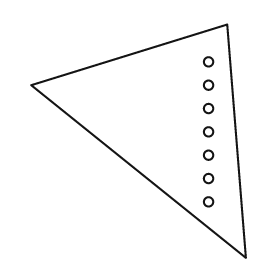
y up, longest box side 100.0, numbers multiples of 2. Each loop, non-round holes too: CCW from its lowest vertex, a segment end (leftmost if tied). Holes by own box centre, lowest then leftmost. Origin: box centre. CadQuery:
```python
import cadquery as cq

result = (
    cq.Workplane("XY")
    .moveTo(46.0, -50.0)
    .lineTo(38.0, 50.0)
    .lineTo(-46.0, 24.0)
    .close()
    .moveTo(30.0, -26.0)
    .circle(2.0)
    .moveTo(30.0, -16.0)
    .circle(2.0)
    .moveTo(30.0, -6.0)
    .circle(2.0)
    .moveTo(30.0, 4.0)
    .circle(2.0)
    .moveTo(30.0, 14.0)
    .circle(2.0)
    .moveTo(30.0, 24.0)
    .circle(2.0)
    .moveTo(30.0, 34.0)
    .circle(2.0)
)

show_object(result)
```